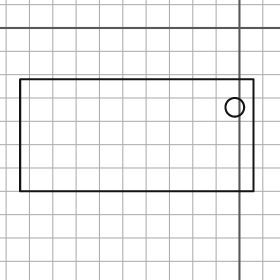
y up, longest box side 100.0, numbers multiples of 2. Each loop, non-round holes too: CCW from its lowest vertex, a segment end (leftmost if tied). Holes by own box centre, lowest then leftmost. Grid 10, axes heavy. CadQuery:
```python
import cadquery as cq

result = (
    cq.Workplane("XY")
    .moveTo(-94.0, -70.0)
    .lineTo(6.0, -70.0)
    .lineTo(6.0, -22.0)
    .lineTo(-94.0, -22.0)
    .close()
    .moveTo(-2.0, -34.0)
    .circle(4.0)
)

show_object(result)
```